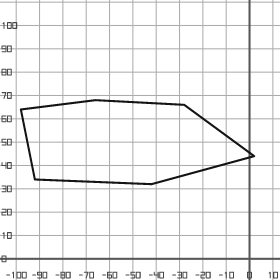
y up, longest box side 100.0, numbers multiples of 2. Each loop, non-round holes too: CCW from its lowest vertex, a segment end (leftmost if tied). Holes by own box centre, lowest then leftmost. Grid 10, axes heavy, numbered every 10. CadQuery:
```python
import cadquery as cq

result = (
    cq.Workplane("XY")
    .moveTo(-42.0, 32.0)
    .lineTo(2.0, 44.0)
    .lineTo(-28.0, 66.0)
    .lineTo(-66.0, 68.0)
    .lineTo(-98.0, 64.0)
    .lineTo(-92.0, 34.0)
    .close()
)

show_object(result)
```